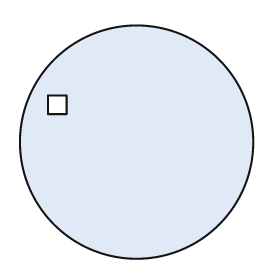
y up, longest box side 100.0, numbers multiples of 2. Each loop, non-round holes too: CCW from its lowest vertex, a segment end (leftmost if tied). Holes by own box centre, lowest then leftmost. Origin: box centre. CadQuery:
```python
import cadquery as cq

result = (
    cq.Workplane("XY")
    .moveTo(0.0, 0.0)
    .circle(50.0)
    .moveTo(-38.0, 12.0)
    .lineTo(-30.0, 12.0)
    .lineTo(-30.0, 20.0)
    .lineTo(-38.0, 20.0)
    .close()
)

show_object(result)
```